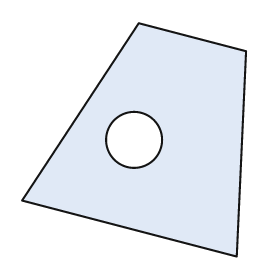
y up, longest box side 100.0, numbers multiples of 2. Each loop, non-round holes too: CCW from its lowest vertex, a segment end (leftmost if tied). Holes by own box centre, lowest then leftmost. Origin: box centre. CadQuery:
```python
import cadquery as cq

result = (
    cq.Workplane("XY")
    .moveTo(44.0, -50.0)
    .lineTo(48.0, 38.0)
    .lineTo(2.0, 50.0)
    .lineTo(-48.0, -26.0)
    .close()
    .moveTo(0.0, 0.0)
    .circle(12.0)
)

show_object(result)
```